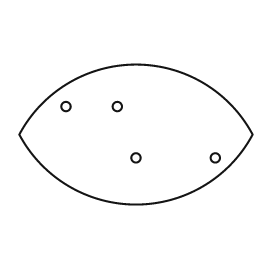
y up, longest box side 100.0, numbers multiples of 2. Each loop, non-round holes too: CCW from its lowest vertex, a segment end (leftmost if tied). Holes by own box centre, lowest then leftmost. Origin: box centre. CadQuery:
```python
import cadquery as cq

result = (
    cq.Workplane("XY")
    .moveTo(-50.0, 0.0)
    .threePointArc((0.0, -30.0), (50.0, 0.0))
    .threePointArc((0.0, 30.0), (-50.0, 0.0))
    .close()
    .moveTo(0.0, -10.0)
    .circle(2.0)
    .moveTo(34.0, -10.0)
    .circle(2.0)
    .moveTo(-30.0, 12.0)
    .circle(2.0)
    .moveTo(-8.0, 12.0)
    .circle(2.0)
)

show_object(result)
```